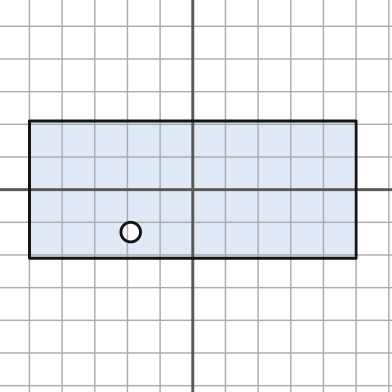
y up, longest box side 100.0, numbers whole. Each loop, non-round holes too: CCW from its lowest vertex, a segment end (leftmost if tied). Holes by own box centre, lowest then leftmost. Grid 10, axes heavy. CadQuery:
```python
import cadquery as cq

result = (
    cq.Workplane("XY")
    .moveTo(-50.0, -21.0)
    .lineTo(50.0, -21.0)
    .lineTo(50.0, 21.0)
    .lineTo(-50.0, 21.0)
    .close()
    .moveTo(-19.0, -13.0)
    .circle(3.0)
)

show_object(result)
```